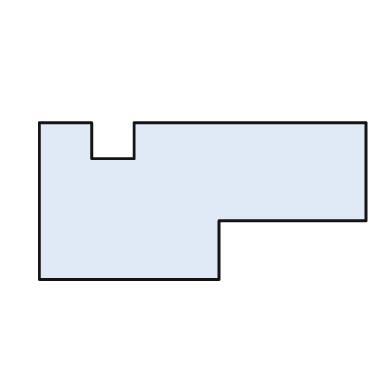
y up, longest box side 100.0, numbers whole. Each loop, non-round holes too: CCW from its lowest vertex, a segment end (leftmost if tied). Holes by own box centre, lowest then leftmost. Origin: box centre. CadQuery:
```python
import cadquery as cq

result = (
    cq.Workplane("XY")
    .moveTo(-50.0, -24.0)
    .lineTo(5.0, -24.0)
    .lineTo(5.0, -6.0)
    .lineTo(50.0, -6.0)
    .lineTo(50.0, 24.0)
    .lineTo(-21.0, 24.0)
    .lineTo(-21.0, 13.0)
    .lineTo(-34.0, 13.0)
    .lineTo(-34.0, 24.0)
    .lineTo(-50.0, 24.0)
    .close()
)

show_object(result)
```